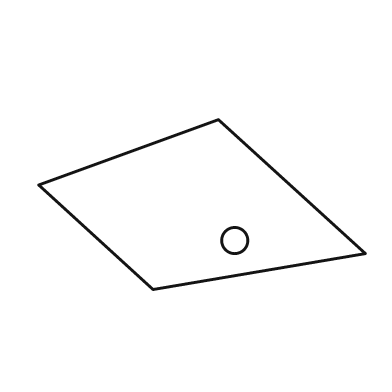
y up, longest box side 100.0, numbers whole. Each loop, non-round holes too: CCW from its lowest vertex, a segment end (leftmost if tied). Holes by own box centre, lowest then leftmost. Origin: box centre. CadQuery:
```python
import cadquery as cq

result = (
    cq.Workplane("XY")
    .moveTo(-15.0, -26.0)
    .lineTo(50.0, -15.0)
    .lineTo(5.0, 26.0)
    .lineTo(-50.0, 6.0)
    .close()
    .moveTo(10.0, -11.0)
    .circle(4.0)
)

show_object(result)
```